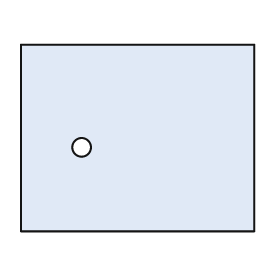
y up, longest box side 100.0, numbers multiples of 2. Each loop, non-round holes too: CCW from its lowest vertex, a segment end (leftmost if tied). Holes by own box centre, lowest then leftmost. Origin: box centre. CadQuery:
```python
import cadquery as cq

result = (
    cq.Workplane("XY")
    .moveTo(-50.0, -40.0)
    .lineTo(50.0, -40.0)
    .lineTo(50.0, 40.0)
    .lineTo(-50.0, 40.0)
    .close()
    .moveTo(-24.0, -4.0)
    .circle(4.0)
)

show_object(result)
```